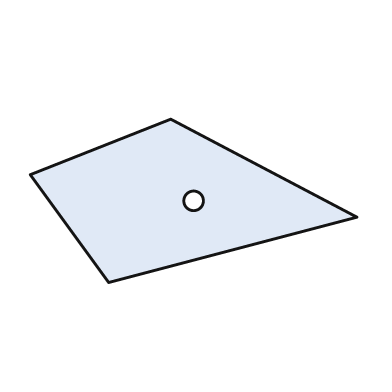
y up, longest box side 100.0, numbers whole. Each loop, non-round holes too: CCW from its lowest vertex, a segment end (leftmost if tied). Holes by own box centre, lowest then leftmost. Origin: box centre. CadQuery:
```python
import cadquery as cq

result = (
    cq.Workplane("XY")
    .moveTo(-26.0, -25.0)
    .lineTo(50.0, -5.0)
    .lineTo(-7.0, 25.0)
    .lineTo(-50.0, 8.0)
    .close()
    .moveTo(0.0, 0.0)
    .circle(3.0)
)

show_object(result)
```